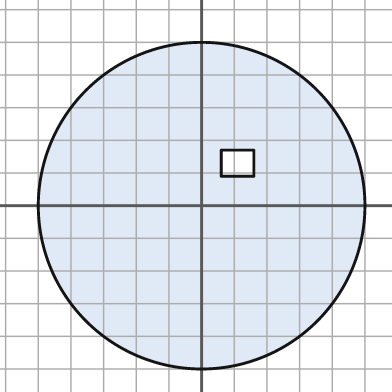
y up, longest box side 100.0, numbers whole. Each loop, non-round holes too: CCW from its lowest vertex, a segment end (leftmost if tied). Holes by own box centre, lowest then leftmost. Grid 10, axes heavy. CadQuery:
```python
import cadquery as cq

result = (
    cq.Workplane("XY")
    .moveTo(0.0, 0.0)
    .circle(50.0)
    .moveTo(6.0, 9.0)
    .lineTo(16.0, 9.0)
    .lineTo(16.0, 17.0)
    .lineTo(6.0, 17.0)
    .close()
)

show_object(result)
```